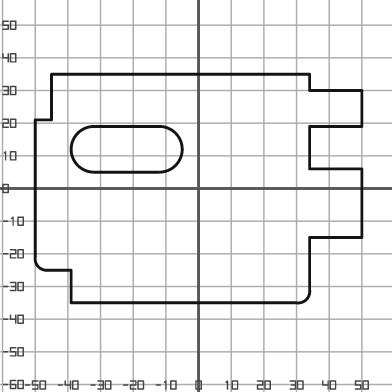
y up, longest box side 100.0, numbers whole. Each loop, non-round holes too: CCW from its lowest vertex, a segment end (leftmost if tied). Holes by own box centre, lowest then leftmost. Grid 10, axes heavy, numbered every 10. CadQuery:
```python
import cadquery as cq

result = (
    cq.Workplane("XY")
    .moveTo(-39.0, -35.0)
    .lineTo(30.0, -35.0)
    .threePointArc((33.0, -34.0), (34.0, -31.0))
    .lineTo(34.0, -15.0)
    .lineTo(50.0, -15.0)
    .lineTo(50.0, 6.0)
    .lineTo(34.0, 6.0)
    .lineTo(34.0, 19.0)
    .lineTo(50.0, 19.0)
    .lineTo(50.0, 30.0)
    .lineTo(34.0, 30.0)
    .lineTo(34.0, 35.0)
    .lineTo(-45.0, 35.0)
    .lineTo(-45.0, 21.0)
    .lineTo(-50.0, 21.0)
    .lineTo(-50.0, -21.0)
    .threePointArc((-49.0, -24.0), (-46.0, -25.0))
    .lineTo(-39.0, -25.0)
    .close()
    .moveTo(-32.0, 5.0)
    .lineTo(-12.0, 5.0)
    .threePointArc((-5.0, 12.0), (-12.0, 19.0))
    .lineTo(-32.0, 19.0)
    .threePointArc((-39.0, 12.0), (-32.0, 5.0))
    .close()
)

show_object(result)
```